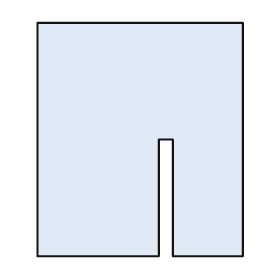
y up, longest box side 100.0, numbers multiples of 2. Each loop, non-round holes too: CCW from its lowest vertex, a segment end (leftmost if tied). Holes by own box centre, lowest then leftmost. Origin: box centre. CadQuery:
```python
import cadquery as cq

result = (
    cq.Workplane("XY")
    .moveTo(-44.0, -50.0)
    .lineTo(8.0, -50.0)
    .lineTo(8.0, 0.0)
    .lineTo(14.0, 0.0)
    .lineTo(14.0, -50.0)
    .lineTo(44.0, -50.0)
    .lineTo(44.0, 50.0)
    .lineTo(-44.0, 50.0)
    .close()
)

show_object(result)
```